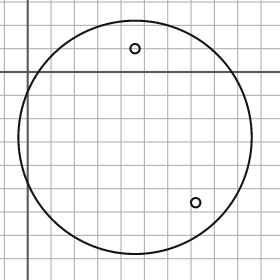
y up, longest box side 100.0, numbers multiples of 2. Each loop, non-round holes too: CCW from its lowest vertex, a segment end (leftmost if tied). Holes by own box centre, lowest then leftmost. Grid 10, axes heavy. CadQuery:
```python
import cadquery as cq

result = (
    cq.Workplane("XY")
    .moveTo(46.0, -28.0)
    .circle(50.0)
    .moveTo(72.0, -56.0)
    .circle(2.0)
    .moveTo(46.0, 10.0)
    .circle(2.0)
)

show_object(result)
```